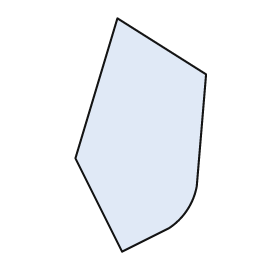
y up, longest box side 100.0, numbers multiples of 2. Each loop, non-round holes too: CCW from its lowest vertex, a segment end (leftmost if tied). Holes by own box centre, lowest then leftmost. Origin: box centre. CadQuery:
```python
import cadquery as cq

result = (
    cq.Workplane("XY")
    .moveTo(-8.0, -50.0)
    .lineTo(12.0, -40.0)
    .threePointArc((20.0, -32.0), (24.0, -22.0))
    .lineTo(28.0, 26.0)
    .lineTo(-10.0, 50.0)
    .lineTo(-28.0, -10.0)
    .close()
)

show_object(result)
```